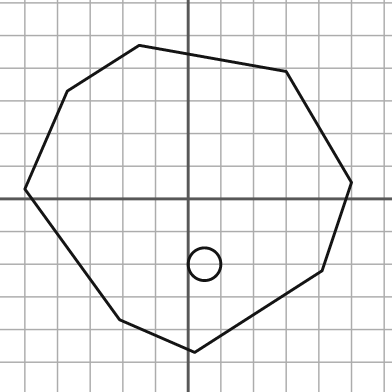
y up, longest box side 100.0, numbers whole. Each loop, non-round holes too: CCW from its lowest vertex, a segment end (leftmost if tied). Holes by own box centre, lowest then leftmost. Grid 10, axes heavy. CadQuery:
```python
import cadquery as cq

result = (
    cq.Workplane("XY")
    .moveTo(2.0, -47.0)
    .lineTo(41.0, -22.0)
    .lineTo(50.0, 5.0)
    .lineTo(30.0, 39.0)
    .lineTo(-15.0, 47.0)
    .lineTo(-37.0, 33.0)
    .lineTo(-50.0, 3.0)
    .lineTo(-21.0, -37.0)
    .close()
    .moveTo(5.0, -20.0)
    .circle(5.0)
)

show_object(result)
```